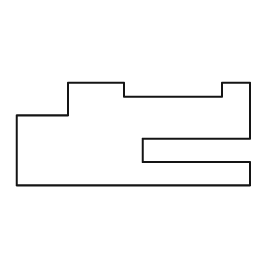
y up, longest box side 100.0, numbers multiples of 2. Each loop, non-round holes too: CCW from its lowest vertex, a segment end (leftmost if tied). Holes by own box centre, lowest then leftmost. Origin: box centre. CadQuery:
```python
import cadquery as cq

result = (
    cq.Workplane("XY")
    .moveTo(-50.0, -22.0)
    .lineTo(50.0, -22.0)
    .lineTo(50.0, -12.0)
    .lineTo(4.0, -12.0)
    .lineTo(4.0, -2.0)
    .lineTo(50.0, -2.0)
    .lineTo(50.0, 22.0)
    .lineTo(38.0, 22.0)
    .lineTo(38.0, 16.0)
    .lineTo(-4.0, 16.0)
    .lineTo(-4.0, 22.0)
    .lineTo(-28.0, 22.0)
    .lineTo(-28.0, 8.0)
    .lineTo(-50.0, 8.0)
    .close()
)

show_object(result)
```